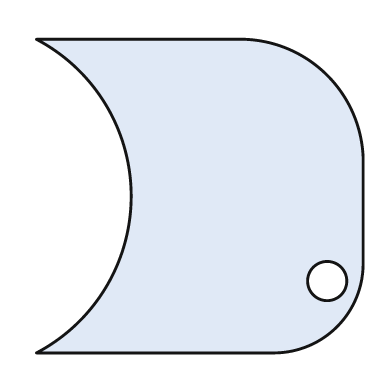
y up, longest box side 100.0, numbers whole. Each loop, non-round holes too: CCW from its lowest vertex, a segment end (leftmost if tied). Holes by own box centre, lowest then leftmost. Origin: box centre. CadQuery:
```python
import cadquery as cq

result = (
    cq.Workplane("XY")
    .moveTo(-50.0, -48.0)
    .lineTo(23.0, -48.0)
    .threePointArc((42.0, -40.0), (50.0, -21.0))
    .lineTo(50.0, 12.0)
    .threePointArc((39.0, 37.0), (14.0, 48.0))
    .lineTo(-50.0, 48.0)
    .threePointArc((-21.0, 0.0), (-50.0, -48.0))
    .close()
    .moveTo(39.0, -26.0)
    .circle(6.0)
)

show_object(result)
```